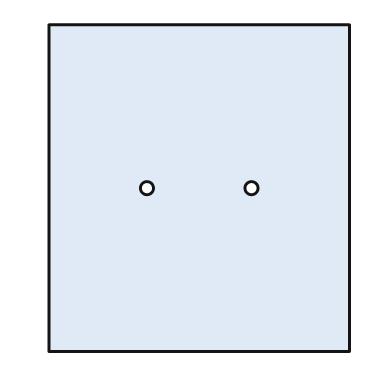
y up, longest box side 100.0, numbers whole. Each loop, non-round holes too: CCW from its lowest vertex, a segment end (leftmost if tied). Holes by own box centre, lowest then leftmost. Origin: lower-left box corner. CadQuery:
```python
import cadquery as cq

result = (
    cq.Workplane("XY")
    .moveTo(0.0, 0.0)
    .lineTo(92.0, 0.0)
    .lineTo(92.0, 100.0)
    .lineTo(0.0, 100.0)
    .close()
    .moveTo(30.0, 50.0)
    .circle(2.0)
    .moveTo(62.0, 50.0)
    .circle(2.0)
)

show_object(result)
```